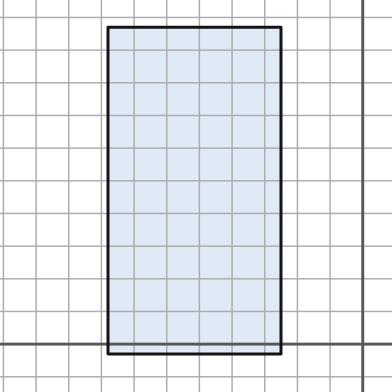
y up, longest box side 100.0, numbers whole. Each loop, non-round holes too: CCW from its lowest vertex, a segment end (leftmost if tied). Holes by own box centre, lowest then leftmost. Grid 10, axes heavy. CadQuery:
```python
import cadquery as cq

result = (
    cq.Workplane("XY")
    .moveTo(-78.0, -3.0)
    .lineTo(-25.0, -3.0)
    .lineTo(-25.0, 97.0)
    .lineTo(-78.0, 97.0)
    .close()
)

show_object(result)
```